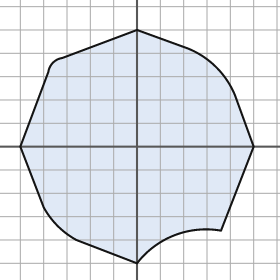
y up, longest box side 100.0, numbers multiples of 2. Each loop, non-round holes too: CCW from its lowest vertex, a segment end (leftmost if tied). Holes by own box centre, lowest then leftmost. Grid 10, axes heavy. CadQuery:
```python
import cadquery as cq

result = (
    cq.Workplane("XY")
    .moveTo(0.0, -50.0)
    .threePointArc((16.0, -38.0), (36.0, -36.0))
    .lineTo(50.0, 0.0)
    .lineTo(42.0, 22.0)
    .threePointArc((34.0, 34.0), (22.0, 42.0))
    .lineTo(0.0, 50.0)
    .lineTo(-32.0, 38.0)
    .threePointArc((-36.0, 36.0), (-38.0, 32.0))
    .lineTo(-50.0, 0.0)
    .lineTo(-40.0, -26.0)
    .threePointArc((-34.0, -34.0), (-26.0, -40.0))
    .close()
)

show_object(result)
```